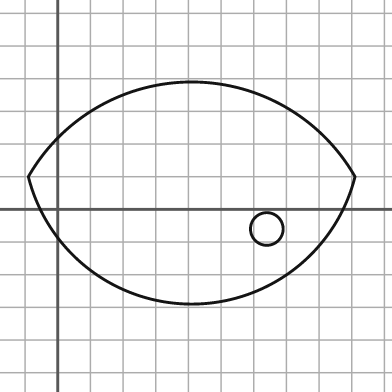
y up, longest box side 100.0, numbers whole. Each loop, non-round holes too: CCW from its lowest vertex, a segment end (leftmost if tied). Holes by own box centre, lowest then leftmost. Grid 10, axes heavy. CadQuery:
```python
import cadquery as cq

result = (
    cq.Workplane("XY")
    .moveTo(-9.0, 10.0)
    .threePointArc((41.0, -29.0), (91.0, 10.0))
    .threePointArc((41.0, 39.0), (-9.0, 10.0))
    .close()
    .moveTo(64.0, -6.0)
    .circle(5.0)
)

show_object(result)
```